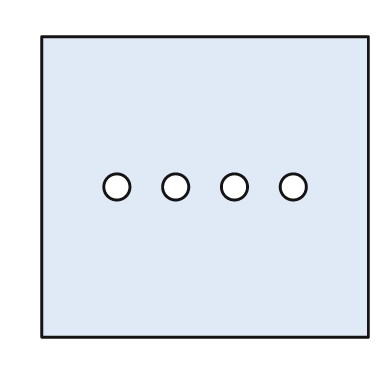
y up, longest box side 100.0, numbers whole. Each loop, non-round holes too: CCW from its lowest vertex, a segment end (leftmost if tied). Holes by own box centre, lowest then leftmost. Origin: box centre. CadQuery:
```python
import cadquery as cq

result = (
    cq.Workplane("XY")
    .moveTo(-50.0, -46.0)
    .lineTo(50.0, -46.0)
    .lineTo(50.0, 46.0)
    .lineTo(-50.0, 46.0)
    .close()
    .moveTo(-27.0, 0.0)
    .circle(4.0)
    .moveTo(-9.0, 0.0)
    .circle(4.0)
    .moveTo(9.0, 0.0)
    .circle(4.0)
    .moveTo(27.0, 0.0)
    .circle(4.0)
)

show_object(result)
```